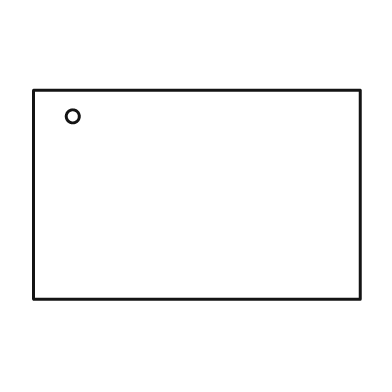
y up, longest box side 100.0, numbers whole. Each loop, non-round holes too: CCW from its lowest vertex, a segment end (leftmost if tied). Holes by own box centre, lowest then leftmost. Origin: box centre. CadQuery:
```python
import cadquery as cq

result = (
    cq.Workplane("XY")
    .moveTo(-50.0, -32.0)
    .lineTo(50.0, -32.0)
    .lineTo(50.0, 32.0)
    .lineTo(-50.0, 32.0)
    .close()
    .moveTo(-38.0, 24.0)
    .circle(2.0)
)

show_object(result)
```